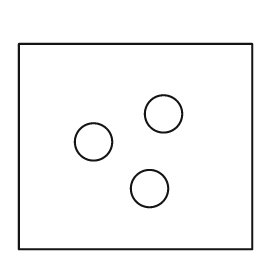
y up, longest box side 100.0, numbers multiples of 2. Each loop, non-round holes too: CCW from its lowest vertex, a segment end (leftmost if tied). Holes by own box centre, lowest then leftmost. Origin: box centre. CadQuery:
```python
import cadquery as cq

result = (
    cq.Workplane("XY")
    .moveTo(-50.0, -44.0)
    .lineTo(50.0, -44.0)
    .lineTo(50.0, 44.0)
    .lineTo(-50.0, 44.0)
    .close()
    .moveTo(6.0, -18.0)
    .circle(8.0)
    .moveTo(-18.0, 2.0)
    .circle(8.0)
    .moveTo(12.0, 14.0)
    .circle(8.0)
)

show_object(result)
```